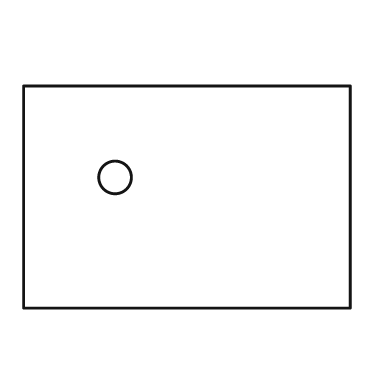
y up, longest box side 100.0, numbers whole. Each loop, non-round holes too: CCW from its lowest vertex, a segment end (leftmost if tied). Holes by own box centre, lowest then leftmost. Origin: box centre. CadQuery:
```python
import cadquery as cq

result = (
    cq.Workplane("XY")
    .moveTo(-50.0, -34.0)
    .lineTo(50.0, -34.0)
    .lineTo(50.0, 34.0)
    .lineTo(-50.0, 34.0)
    .close()
    .moveTo(-22.0, 6.0)
    .circle(5.0)
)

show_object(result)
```